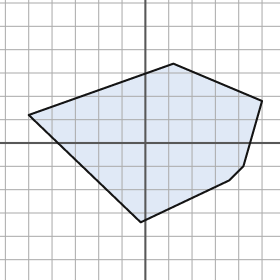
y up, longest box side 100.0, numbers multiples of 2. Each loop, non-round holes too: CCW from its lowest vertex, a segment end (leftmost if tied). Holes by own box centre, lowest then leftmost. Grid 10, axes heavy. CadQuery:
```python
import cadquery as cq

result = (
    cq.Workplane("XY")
    .moveTo(-2.0, -34.0)
    .lineTo(36.0, -16.0)
    .lineTo(42.0, -10.0)
    .lineTo(50.0, 18.0)
    .lineTo(12.0, 34.0)
    .lineTo(-50.0, 12.0)
    .close()
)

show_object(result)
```